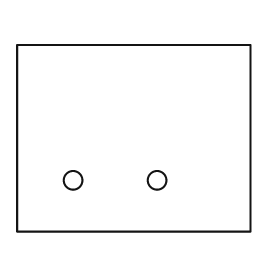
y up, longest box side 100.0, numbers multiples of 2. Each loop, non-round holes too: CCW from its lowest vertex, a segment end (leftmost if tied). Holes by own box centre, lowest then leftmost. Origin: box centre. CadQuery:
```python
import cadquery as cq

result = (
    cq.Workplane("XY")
    .moveTo(-50.0, -40.0)
    .lineTo(50.0, -40.0)
    .lineTo(50.0, 40.0)
    .lineTo(-50.0, 40.0)
    .close()
    .moveTo(-26.0, -18.0)
    .circle(4.0)
    .moveTo(10.0, -18.0)
    .circle(4.0)
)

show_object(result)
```